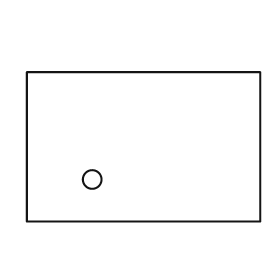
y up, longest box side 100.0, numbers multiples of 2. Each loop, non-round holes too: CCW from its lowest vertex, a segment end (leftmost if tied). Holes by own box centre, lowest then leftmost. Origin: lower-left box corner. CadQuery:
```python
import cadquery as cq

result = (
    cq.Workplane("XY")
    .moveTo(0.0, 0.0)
    .lineTo(100.0, 0.0)
    .lineTo(100.0, 64.0)
    .lineTo(0.0, 64.0)
    .close()
    .moveTo(28.0, 18.0)
    .circle(4.0)
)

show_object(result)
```